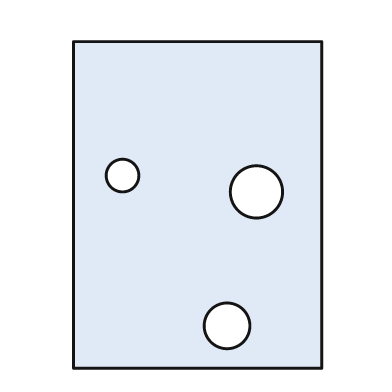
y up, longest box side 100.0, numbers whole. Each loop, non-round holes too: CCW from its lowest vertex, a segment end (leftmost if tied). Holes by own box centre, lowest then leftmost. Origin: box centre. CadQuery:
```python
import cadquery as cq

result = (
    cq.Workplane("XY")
    .moveTo(-38.0, -50.0)
    .lineTo(38.0, -50.0)
    .lineTo(38.0, 50.0)
    .lineTo(-38.0, 50.0)
    .close()
    .moveTo(9.0, -37.0)
    .circle(7.0)
    .moveTo(18.0, 4.0)
    .circle(8.0)
    .moveTo(-23.0, 9.0)
    .circle(5.0)
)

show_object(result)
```